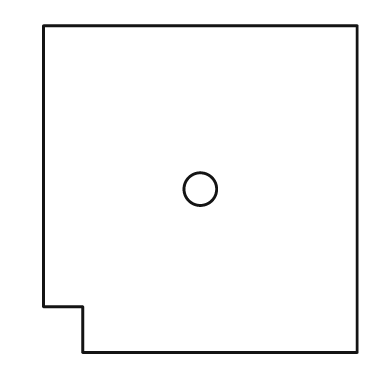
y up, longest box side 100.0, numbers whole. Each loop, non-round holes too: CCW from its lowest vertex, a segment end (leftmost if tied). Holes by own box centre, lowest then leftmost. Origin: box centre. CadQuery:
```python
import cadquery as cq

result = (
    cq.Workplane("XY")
    .moveTo(-36.0, -50.0)
    .lineTo(48.0, -50.0)
    .lineTo(48.0, 50.0)
    .lineTo(-48.0, 50.0)
    .lineTo(-48.0, -36.0)
    .lineTo(-36.0, -36.0)
    .close()
    .moveTo(0.0, 0.0)
    .circle(5.0)
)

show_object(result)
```